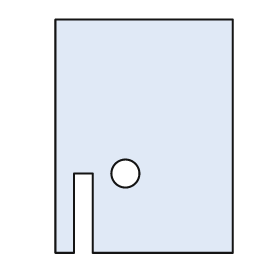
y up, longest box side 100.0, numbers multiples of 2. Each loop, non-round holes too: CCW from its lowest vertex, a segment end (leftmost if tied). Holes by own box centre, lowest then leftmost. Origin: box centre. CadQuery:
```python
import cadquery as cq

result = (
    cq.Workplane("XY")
    .moveTo(-38.0, -50.0)
    .lineTo(-30.0, -50.0)
    .lineTo(-30.0, -16.0)
    .lineTo(-22.0, -16.0)
    .lineTo(-22.0, -50.0)
    .lineTo(38.0, -50.0)
    .lineTo(38.0, 50.0)
    .lineTo(-38.0, 50.0)
    .close()
    .moveTo(-8.0, -16.0)
    .circle(6.0)
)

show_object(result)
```